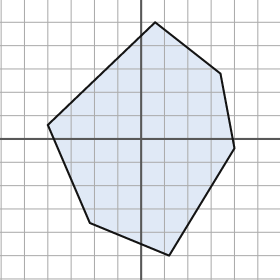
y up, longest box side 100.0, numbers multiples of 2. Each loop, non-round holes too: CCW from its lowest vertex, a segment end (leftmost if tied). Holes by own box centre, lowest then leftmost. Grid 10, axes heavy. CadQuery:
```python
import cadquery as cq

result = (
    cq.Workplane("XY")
    .moveTo(12.0, -50.0)
    .lineTo(40.0, -4.0)
    .lineTo(34.0, 28.0)
    .lineTo(6.0, 50.0)
    .lineTo(-40.0, 6.0)
    .lineTo(-22.0, -36.0)
    .close()
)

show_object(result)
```